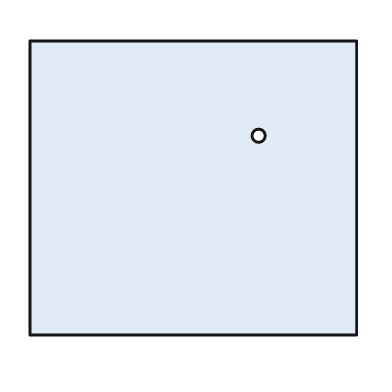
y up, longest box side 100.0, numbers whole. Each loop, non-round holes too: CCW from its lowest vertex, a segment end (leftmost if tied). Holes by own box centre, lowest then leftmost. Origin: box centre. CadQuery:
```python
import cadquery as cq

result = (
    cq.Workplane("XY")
    .moveTo(-50.0, -45.0)
    .lineTo(50.0, -45.0)
    .lineTo(50.0, 45.0)
    .lineTo(-50.0, 45.0)
    .close()
    .moveTo(20.0, 16.0)
    .circle(2.0)
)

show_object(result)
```